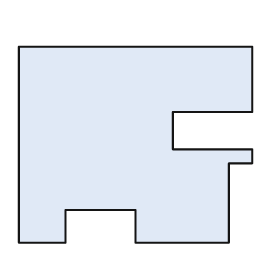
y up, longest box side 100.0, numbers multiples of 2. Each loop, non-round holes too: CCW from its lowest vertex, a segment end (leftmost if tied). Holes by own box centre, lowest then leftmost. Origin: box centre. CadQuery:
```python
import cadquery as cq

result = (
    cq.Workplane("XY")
    .moveTo(-50.0, -42.0)
    .lineTo(-30.0, -42.0)
    .lineTo(-30.0, -28.0)
    .lineTo(0.0, -28.0)
    .lineTo(0.0, -42.0)
    .lineTo(40.0, -42.0)
    .lineTo(40.0, -8.0)
    .lineTo(50.0, -8.0)
    .lineTo(50.0, -2.0)
    .lineTo(16.0, -2.0)
    .lineTo(16.0, 14.0)
    .lineTo(50.0, 14.0)
    .lineTo(50.0, 42.0)
    .lineTo(-50.0, 42.0)
    .close()
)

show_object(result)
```